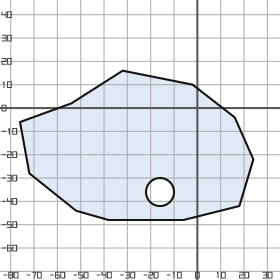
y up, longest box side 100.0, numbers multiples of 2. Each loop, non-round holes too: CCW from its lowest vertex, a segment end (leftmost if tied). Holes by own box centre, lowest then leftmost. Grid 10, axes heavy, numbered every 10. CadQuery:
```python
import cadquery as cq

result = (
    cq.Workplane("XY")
    .moveTo(-38.0, -48.0)
    .lineTo(-6.0, -48.0)
    .lineTo(18.0, -42.0)
    .lineTo(24.0, -22.0)
    .lineTo(16.0, -4.0)
    .lineTo(-2.0, 10.0)
    .lineTo(-32.0, 16.0)
    .lineTo(-54.0, 2.0)
    .lineTo(-76.0, -6.0)
    .lineTo(-72.0, -28.0)
    .lineTo(-52.0, -44.0)
    .close()
    .moveTo(-16.0, -36.0)
    .circle(6.0)
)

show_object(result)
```